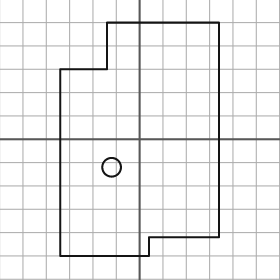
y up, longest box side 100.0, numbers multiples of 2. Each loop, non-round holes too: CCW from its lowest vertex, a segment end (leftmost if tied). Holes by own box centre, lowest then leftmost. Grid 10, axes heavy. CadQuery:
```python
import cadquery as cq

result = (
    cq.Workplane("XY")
    .moveTo(-34.0, -50.0)
    .lineTo(4.0, -50.0)
    .lineTo(4.0, -42.0)
    .lineTo(34.0, -42.0)
    .lineTo(34.0, 50.0)
    .lineTo(-14.0, 50.0)
    .lineTo(-14.0, 30.0)
    .lineTo(-34.0, 30.0)
    .close()
    .moveTo(-12.0, -12.0)
    .circle(4.0)
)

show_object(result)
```